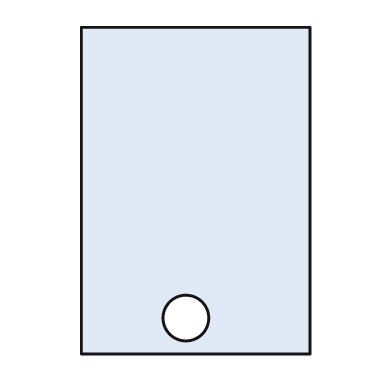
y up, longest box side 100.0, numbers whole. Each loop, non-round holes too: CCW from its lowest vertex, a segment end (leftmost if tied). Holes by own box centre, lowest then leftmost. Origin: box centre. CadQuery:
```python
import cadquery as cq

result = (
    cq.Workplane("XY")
    .moveTo(-35.0, -50.0)
    .lineTo(35.0, -50.0)
    .lineTo(35.0, 50.0)
    .lineTo(-35.0, 50.0)
    .close()
    .moveTo(-3.0, -39.0)
    .circle(7.0)
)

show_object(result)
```